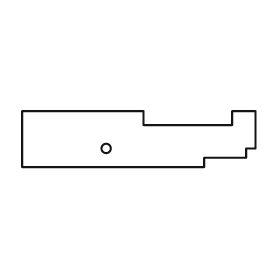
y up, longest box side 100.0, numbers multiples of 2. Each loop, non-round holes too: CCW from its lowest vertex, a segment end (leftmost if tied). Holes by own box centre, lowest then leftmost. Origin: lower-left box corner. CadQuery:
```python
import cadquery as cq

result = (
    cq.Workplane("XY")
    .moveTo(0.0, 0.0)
    .lineTo(78.0, 0.0)
    .lineTo(78.0, 4.0)
    .lineTo(96.0, 4.0)
    .lineTo(96.0, 8.0)
    .lineTo(100.0, 8.0)
    .lineTo(100.0, 24.0)
    .lineTo(90.0, 24.0)
    .lineTo(90.0, 18.0)
    .lineTo(52.0, 18.0)
    .lineTo(52.0, 24.0)
    .lineTo(0.0, 24.0)
    .close()
    .moveTo(36.0, 8.0)
    .circle(2.0)
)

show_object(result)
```